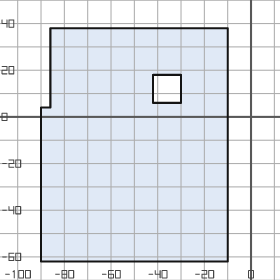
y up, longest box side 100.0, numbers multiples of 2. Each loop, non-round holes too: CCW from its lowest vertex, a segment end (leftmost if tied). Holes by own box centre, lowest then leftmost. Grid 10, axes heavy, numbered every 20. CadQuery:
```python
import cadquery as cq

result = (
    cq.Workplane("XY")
    .moveTo(-90.0, -62.0)
    .lineTo(-10.0, -62.0)
    .lineTo(-10.0, 38.0)
    .lineTo(-86.0, 38.0)
    .lineTo(-86.0, 4.0)
    .lineTo(-90.0, 4.0)
    .close()
    .moveTo(-42.0, 6.0)
    .lineTo(-30.0, 6.0)
    .lineTo(-30.0, 18.0)
    .lineTo(-42.0, 18.0)
    .close()
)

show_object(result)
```